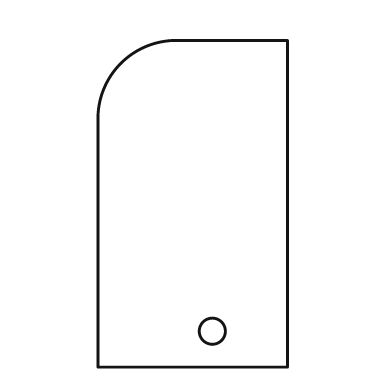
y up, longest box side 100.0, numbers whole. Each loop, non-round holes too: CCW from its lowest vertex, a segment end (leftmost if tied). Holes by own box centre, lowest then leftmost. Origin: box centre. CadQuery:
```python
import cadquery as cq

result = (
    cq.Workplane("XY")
    .moveTo(-29.0, -50.0)
    .lineTo(29.0, -50.0)
    .lineTo(29.0, 50.0)
    .lineTo(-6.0, 50.0)
    .threePointArc((-22.0, 43.0), (-29.0, 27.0))
    .close()
    .moveTo(6.0, -39.0)
    .circle(4.0)
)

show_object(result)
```